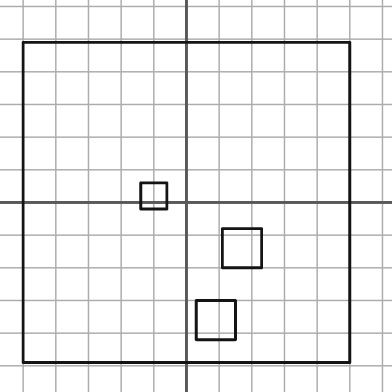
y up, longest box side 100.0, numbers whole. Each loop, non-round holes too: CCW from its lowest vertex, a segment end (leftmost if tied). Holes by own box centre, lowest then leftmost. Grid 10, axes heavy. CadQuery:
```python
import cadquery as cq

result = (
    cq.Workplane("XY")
    .moveTo(-50.0, -49.0)
    .lineTo(50.0, -49.0)
    .lineTo(50.0, 49.0)
    .lineTo(-50.0, 49.0)
    .close()
    .moveTo(3.0, -42.0)
    .lineTo(15.0, -42.0)
    .lineTo(15.0, -30.0)
    .lineTo(3.0, -30.0)
    .close()
    .moveTo(11.0, -20.0)
    .lineTo(23.0, -20.0)
    .lineTo(23.0, -8.0)
    .lineTo(11.0, -8.0)
    .close()
    .moveTo(-14.0, -2.0)
    .lineTo(-6.0, -2.0)
    .lineTo(-6.0, 6.0)
    .lineTo(-14.0, 6.0)
    .close()
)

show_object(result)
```